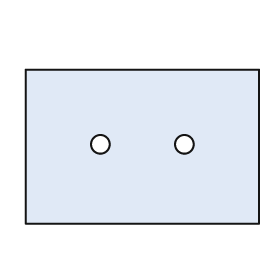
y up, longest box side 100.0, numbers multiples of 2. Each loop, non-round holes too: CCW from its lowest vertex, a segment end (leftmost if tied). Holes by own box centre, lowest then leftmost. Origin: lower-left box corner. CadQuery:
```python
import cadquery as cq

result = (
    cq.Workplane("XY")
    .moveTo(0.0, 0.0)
    .lineTo(100.0, 0.0)
    .lineTo(100.0, 66.0)
    .lineTo(0.0, 66.0)
    .close()
    .moveTo(32.0, 34.0)
    .circle(4.0)
    .moveTo(68.0, 34.0)
    .circle(4.0)
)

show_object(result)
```